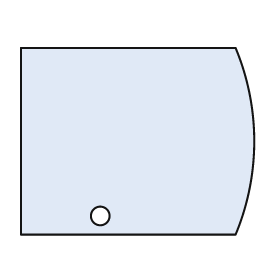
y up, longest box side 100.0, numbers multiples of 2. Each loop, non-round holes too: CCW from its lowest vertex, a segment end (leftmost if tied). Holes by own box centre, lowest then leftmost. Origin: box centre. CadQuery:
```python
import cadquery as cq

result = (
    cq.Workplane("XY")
    .moveTo(-50.0, -40.0)
    .lineTo(42.0, -40.0)
    .threePointArc((50.0, 0.0), (42.0, 40.0))
    .lineTo(-50.0, 40.0)
    .close()
    .moveTo(-16.0, -32.0)
    .circle(4.0)
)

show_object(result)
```